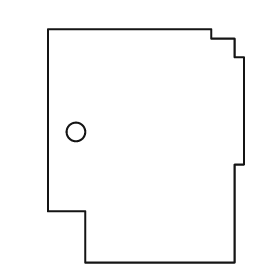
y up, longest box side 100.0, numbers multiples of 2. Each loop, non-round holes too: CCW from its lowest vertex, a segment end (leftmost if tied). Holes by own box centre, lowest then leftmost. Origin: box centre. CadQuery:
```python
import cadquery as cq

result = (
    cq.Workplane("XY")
    .moveTo(-26.0, -50.0)
    .lineTo(38.0, -50.0)
    .lineTo(38.0, -8.0)
    .lineTo(42.0, -8.0)
    .lineTo(42.0, 38.0)
    .lineTo(38.0, 38.0)
    .lineTo(38.0, 46.0)
    .lineTo(28.0, 46.0)
    .lineTo(28.0, 50.0)
    .lineTo(-42.0, 50.0)
    .lineTo(-42.0, -28.0)
    .lineTo(-26.0, -28.0)
    .close()
    .moveTo(-30.0, 6.0)
    .circle(4.0)
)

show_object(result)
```